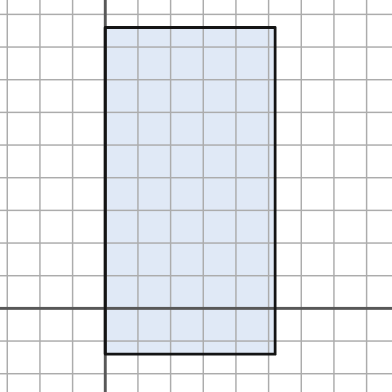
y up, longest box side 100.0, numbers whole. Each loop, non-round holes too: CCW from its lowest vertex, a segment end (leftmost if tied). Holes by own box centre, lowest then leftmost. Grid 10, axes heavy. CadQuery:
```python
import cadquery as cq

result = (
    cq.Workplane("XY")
    .moveTo(0.0, -14.0)
    .lineTo(52.0, -14.0)
    .lineTo(52.0, 86.0)
    .lineTo(0.0, 86.0)
    .close()
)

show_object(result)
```